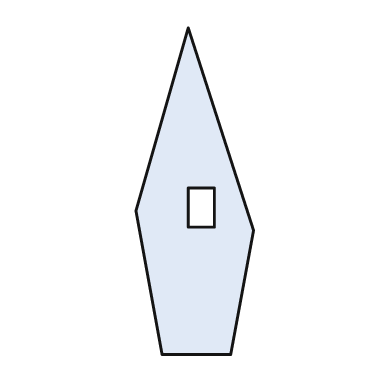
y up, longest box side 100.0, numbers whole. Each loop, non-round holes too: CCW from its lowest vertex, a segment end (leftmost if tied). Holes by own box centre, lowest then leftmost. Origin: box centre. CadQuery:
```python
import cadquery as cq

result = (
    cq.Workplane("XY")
    .moveTo(-10.0, -50.0)
    .lineTo(11.0, -50.0)
    .lineTo(18.0, -12.0)
    .lineTo(-2.0, 50.0)
    .lineTo(-18.0, -6.0)
    .close()
    .moveTo(-2.0, -11.0)
    .lineTo(6.0, -11.0)
    .lineTo(6.0, 1.0)
    .lineTo(-2.0, 1.0)
    .close()
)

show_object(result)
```